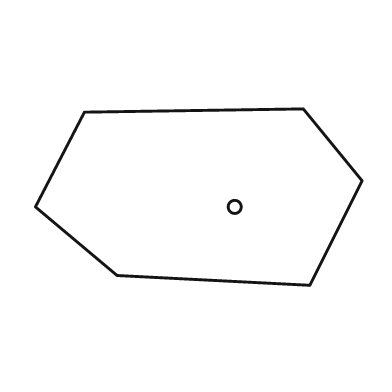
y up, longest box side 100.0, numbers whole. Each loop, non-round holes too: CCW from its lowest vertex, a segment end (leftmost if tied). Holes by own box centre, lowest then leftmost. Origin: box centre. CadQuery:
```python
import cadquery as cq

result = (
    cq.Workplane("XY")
    .moveTo(34.0, -27.0)
    .lineTo(50.0, 5.0)
    .lineTo(32.0, 27.0)
    .lineTo(-35.0, 26.0)
    .lineTo(-50.0, -3.0)
    .lineTo(-25.0, -24.0)
    .close()
    .moveTo(11.0, -3.0)
    .circle(2.0)
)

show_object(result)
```